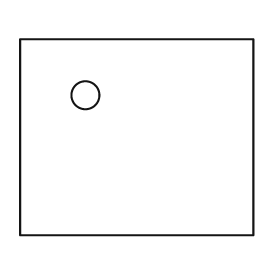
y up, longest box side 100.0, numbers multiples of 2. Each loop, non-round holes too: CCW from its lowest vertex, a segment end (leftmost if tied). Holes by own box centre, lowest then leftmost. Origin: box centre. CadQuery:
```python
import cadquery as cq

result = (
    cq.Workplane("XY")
    .moveTo(-50.0, -42.0)
    .lineTo(50.0, -42.0)
    .lineTo(50.0, 42.0)
    .lineTo(-50.0, 42.0)
    .close()
    .moveTo(-22.0, 18.0)
    .circle(6.0)
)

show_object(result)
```